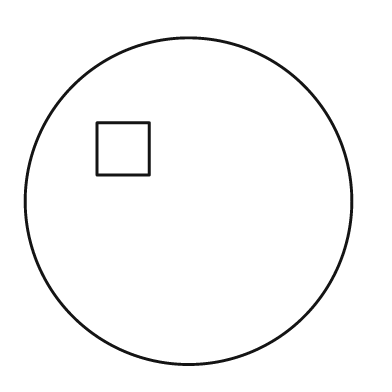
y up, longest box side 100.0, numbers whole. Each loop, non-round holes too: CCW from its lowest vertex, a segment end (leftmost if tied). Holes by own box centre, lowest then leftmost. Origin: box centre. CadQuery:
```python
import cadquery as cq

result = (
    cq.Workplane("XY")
    .moveTo(0.0, 0.0)
    .circle(50.0)
    .moveTo(-28.0, 8.0)
    .lineTo(-12.0, 8.0)
    .lineTo(-12.0, 24.0)
    .lineTo(-28.0, 24.0)
    .close()
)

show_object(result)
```